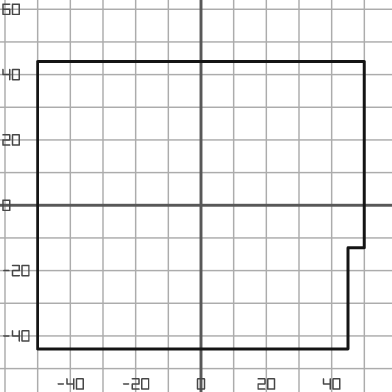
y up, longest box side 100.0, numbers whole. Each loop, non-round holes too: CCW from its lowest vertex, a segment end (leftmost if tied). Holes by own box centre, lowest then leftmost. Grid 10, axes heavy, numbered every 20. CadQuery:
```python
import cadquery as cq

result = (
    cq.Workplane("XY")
    .moveTo(-50.0, -44.0)
    .lineTo(45.0, -44.0)
    .lineTo(45.0, -13.0)
    .lineTo(50.0, -13.0)
    .lineTo(50.0, 44.0)
    .lineTo(-50.0, 44.0)
    .close()
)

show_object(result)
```